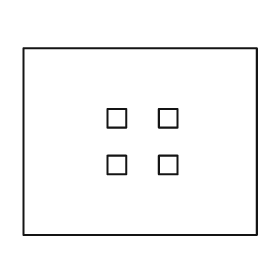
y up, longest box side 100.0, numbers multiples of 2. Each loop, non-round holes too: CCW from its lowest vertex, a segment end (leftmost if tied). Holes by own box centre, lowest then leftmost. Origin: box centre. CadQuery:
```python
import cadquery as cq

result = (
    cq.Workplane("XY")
    .moveTo(-50.0, -40.0)
    .lineTo(50.0, -40.0)
    .lineTo(50.0, 40.0)
    .lineTo(-50.0, 40.0)
    .close()
    .moveTo(-14.0, -14.0)
    .lineTo(-6.0, -14.0)
    .lineTo(-6.0, -6.0)
    .lineTo(-14.0, -6.0)
    .close()
    .moveTo(8.0, -14.0)
    .lineTo(16.0, -14.0)
    .lineTo(16.0, -6.0)
    .lineTo(8.0, -6.0)
    .close()
    .moveTo(-14.0, 6.0)
    .lineTo(-6.0, 6.0)
    .lineTo(-6.0, 14.0)
    .lineTo(-14.0, 14.0)
    .close()
    .moveTo(8.0, 6.0)
    .lineTo(16.0, 6.0)
    .lineTo(16.0, 14.0)
    .lineTo(8.0, 14.0)
    .close()
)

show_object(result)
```